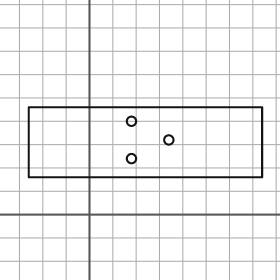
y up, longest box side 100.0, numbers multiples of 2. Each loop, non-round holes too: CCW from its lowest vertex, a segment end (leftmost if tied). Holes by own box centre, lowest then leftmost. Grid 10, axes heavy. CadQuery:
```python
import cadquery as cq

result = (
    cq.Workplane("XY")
    .moveTo(-26.0, 16.0)
    .lineTo(74.0, 16.0)
    .lineTo(74.0, 46.0)
    .lineTo(-26.0, 46.0)
    .close()
    .moveTo(18.0, 24.0)
    .circle(2.0)
    .moveTo(34.0, 32.0)
    .circle(2.0)
    .moveTo(18.0, 40.0)
    .circle(2.0)
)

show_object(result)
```